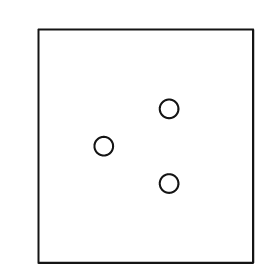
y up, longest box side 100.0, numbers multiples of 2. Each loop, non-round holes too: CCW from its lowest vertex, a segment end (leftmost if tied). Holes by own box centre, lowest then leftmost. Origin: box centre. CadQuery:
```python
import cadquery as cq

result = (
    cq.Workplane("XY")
    .moveTo(-46.0, -50.0)
    .lineTo(46.0, -50.0)
    .lineTo(46.0, 50.0)
    .lineTo(-46.0, 50.0)
    .close()
    .moveTo(10.0, -16.0)
    .circle(4.0)
    .moveTo(-18.0, 0.0)
    .circle(4.0)
    .moveTo(10.0, 16.0)
    .circle(4.0)
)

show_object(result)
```